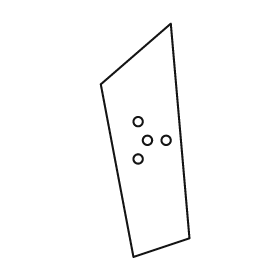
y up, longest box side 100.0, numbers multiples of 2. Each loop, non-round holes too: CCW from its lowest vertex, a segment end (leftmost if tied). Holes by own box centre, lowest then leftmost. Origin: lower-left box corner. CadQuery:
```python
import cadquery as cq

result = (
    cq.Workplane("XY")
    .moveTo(14.0, 0.0)
    .lineTo(38.0, 8.0)
    .lineTo(30.0, 100.0)
    .lineTo(0.0, 74.0)
    .close()
    .moveTo(16.0, 42.0)
    .circle(2.0)
    .moveTo(20.0, 50.0)
    .circle(2.0)
    .moveTo(28.0, 50.0)
    .circle(2.0)
    .moveTo(16.0, 58.0)
    .circle(2.0)
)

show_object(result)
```